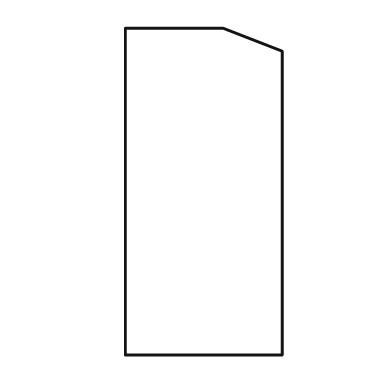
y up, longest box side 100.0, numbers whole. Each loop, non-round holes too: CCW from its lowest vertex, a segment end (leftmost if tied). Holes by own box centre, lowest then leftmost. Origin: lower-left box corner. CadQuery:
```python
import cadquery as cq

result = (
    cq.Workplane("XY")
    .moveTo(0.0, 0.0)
    .lineTo(48.0, 0.0)
    .lineTo(48.0, 93.0)
    .lineTo(30.0, 100.0)
    .lineTo(0.0, 100.0)
    .close()
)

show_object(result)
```